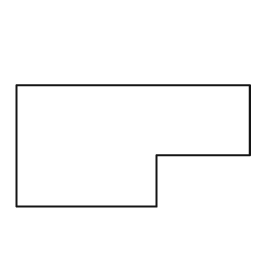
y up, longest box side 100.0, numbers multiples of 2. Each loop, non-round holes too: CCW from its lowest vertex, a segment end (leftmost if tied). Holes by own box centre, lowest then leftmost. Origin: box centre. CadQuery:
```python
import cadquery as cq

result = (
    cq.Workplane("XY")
    .moveTo(-50.0, -26.0)
    .lineTo(10.0, -26.0)
    .lineTo(10.0, -4.0)
    .lineTo(50.0, -4.0)
    .lineTo(50.0, 26.0)
    .lineTo(-50.0, 26.0)
    .close()
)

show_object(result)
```